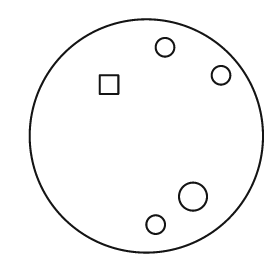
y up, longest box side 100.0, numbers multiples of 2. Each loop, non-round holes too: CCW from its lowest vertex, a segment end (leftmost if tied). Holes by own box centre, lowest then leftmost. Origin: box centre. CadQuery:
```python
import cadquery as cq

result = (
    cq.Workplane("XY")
    .moveTo(0.0, 0.0)
    .circle(50.0)
    .moveTo(4.0, -38.0)
    .circle(4.0)
    .moveTo(20.0, -26.0)
    .circle(6.0)
    .moveTo(-20.0, 18.0)
    .lineTo(-12.0, 18.0)
    .lineTo(-12.0, 26.0)
    .lineTo(-20.0, 26.0)
    .close()
    .moveTo(32.0, 26.0)
    .circle(4.0)
    .moveTo(8.0, 38.0)
    .circle(4.0)
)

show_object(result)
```